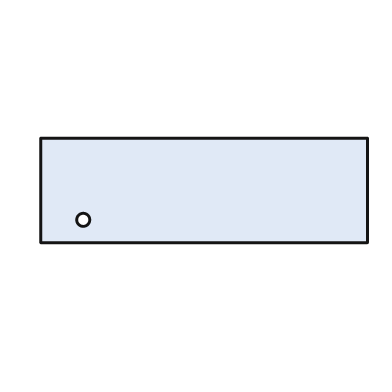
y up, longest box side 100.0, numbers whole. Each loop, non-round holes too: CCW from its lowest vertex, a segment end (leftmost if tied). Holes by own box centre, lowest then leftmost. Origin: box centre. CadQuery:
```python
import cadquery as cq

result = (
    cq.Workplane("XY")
    .moveTo(-50.0, -16.0)
    .lineTo(50.0, -16.0)
    .lineTo(50.0, 16.0)
    .lineTo(-50.0, 16.0)
    .close()
    .moveTo(-37.0, -9.0)
    .circle(2.0)
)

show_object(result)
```